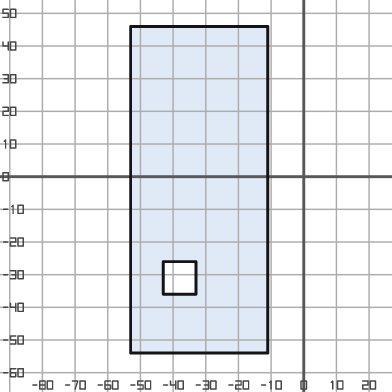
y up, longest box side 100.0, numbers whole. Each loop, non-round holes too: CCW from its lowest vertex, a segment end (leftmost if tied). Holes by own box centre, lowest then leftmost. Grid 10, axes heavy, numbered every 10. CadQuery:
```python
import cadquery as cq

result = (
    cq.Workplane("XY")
    .moveTo(-53.0, -54.0)
    .lineTo(-11.0, -54.0)
    .lineTo(-11.0, 46.0)
    .lineTo(-53.0, 46.0)
    .close()
    .moveTo(-43.0, -36.0)
    .lineTo(-33.0, -36.0)
    .lineTo(-33.0, -26.0)
    .lineTo(-43.0, -26.0)
    .close()
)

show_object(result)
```